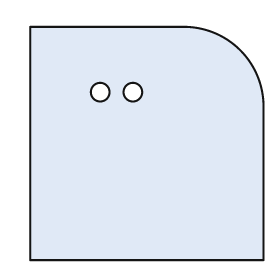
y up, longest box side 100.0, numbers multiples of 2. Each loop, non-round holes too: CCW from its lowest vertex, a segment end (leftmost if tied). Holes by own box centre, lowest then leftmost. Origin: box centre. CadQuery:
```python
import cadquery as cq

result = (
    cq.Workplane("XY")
    .moveTo(-50.0, -50.0)
    .lineTo(50.0, -50.0)
    .lineTo(50.0, 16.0)
    .threePointArc((40.0, 40.0), (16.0, 50.0))
    .lineTo(-50.0, 50.0)
    .close()
    .moveTo(-20.0, 22.0)
    .circle(4.0)
    .moveTo(-6.0, 22.0)
    .circle(4.0)
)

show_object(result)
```